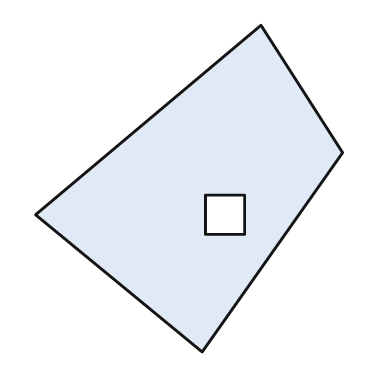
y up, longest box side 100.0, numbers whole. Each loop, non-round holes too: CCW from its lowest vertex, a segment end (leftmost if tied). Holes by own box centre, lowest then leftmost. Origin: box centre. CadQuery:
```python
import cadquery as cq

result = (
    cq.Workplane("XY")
    .moveTo(4.0, -50.0)
    .lineTo(47.0, 11.0)
    .lineTo(22.0, 50.0)
    .lineTo(-47.0, -8.0)
    .close()
    .moveTo(5.0, -14.0)
    .lineTo(17.0, -14.0)
    .lineTo(17.0, -2.0)
    .lineTo(5.0, -2.0)
    .close()
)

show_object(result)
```